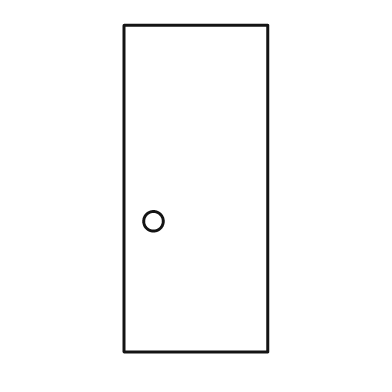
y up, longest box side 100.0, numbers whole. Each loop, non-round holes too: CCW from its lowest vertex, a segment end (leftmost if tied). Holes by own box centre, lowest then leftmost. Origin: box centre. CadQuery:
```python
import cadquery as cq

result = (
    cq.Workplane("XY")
    .moveTo(-22.0, -50.0)
    .lineTo(22.0, -50.0)
    .lineTo(22.0, 50.0)
    .lineTo(-22.0, 50.0)
    .close()
    .moveTo(-13.0, -10.0)
    .circle(3.0)
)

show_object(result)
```